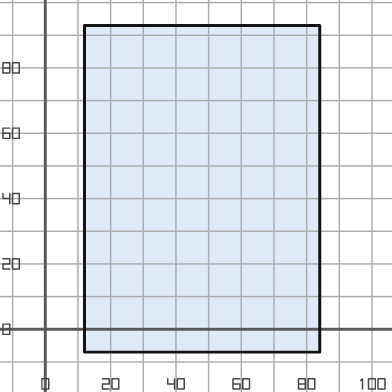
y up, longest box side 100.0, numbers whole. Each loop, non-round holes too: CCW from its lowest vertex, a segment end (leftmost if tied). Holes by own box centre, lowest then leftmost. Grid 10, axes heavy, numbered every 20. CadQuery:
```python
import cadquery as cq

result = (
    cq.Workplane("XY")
    .moveTo(12.0, -7.0)
    .lineTo(84.0, -7.0)
    .lineTo(84.0, 93.0)
    .lineTo(12.0, 93.0)
    .close()
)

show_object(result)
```